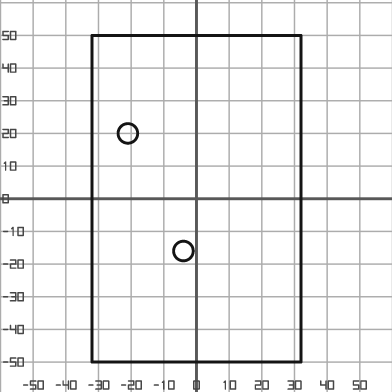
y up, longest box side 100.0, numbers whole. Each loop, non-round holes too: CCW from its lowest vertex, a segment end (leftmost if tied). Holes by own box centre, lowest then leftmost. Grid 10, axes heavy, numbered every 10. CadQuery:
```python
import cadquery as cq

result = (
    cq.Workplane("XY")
    .moveTo(-32.0, -50.0)
    .lineTo(32.0, -50.0)
    .lineTo(32.0, 50.0)
    .lineTo(-32.0, 50.0)
    .close()
    .moveTo(-4.0, -16.0)
    .circle(3.0)
    .moveTo(-21.0, 20.0)
    .circle(3.0)
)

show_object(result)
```